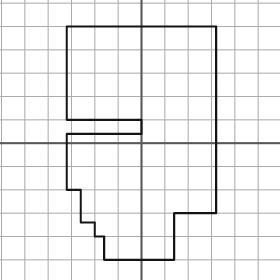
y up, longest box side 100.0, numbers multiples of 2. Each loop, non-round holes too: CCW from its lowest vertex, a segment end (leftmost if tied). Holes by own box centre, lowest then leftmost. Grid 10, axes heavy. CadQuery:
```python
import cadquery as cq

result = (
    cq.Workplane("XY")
    .moveTo(-16.0, -50.0)
    .lineTo(14.0, -50.0)
    .lineTo(14.0, -30.0)
    .lineTo(32.0, -30.0)
    .lineTo(32.0, 50.0)
    .lineTo(-32.0, 50.0)
    .lineTo(-32.0, 10.0)
    .lineTo(0.0, 10.0)
    .lineTo(0.0, 4.0)
    .lineTo(-32.0, 4.0)
    .lineTo(-32.0, -20.0)
    .lineTo(-26.0, -20.0)
    .lineTo(-26.0, -34.0)
    .lineTo(-20.0, -34.0)
    .lineTo(-20.0, -40.0)
    .lineTo(-16.0, -40.0)
    .close()
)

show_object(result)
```